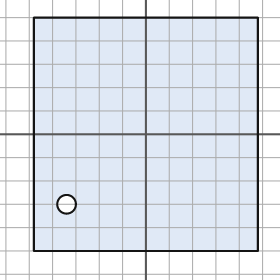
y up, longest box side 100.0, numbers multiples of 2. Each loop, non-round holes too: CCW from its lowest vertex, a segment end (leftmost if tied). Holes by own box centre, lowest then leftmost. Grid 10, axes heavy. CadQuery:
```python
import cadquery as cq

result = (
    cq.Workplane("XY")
    .moveTo(-48.0, -50.0)
    .lineTo(48.0, -50.0)
    .lineTo(48.0, 50.0)
    .lineTo(-48.0, 50.0)
    .close()
    .moveTo(-34.0, -30.0)
    .circle(4.0)
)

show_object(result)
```